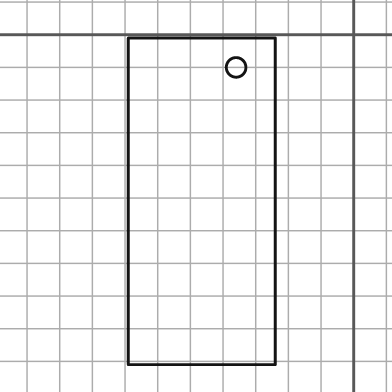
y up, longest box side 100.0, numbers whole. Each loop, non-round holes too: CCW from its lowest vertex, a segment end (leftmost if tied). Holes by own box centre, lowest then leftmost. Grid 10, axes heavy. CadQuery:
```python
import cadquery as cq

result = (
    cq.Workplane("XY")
    .moveTo(-69.0, -101.0)
    .lineTo(-24.0, -101.0)
    .lineTo(-24.0, -1.0)
    .lineTo(-69.0, -1.0)
    .close()
    .moveTo(-36.0, -10.0)
    .circle(3.0)
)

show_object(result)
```